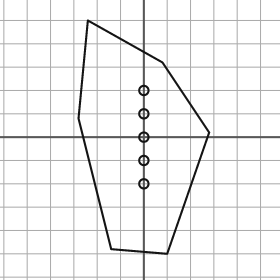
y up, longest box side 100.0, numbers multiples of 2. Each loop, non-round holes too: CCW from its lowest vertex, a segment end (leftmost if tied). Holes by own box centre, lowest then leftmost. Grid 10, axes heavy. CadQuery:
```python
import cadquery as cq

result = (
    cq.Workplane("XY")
    .moveTo(10.0, -50.0)
    .lineTo(28.0, 2.0)
    .lineTo(8.0, 32.0)
    .lineTo(-24.0, 50.0)
    .lineTo(-28.0, 8.0)
    .lineTo(-14.0, -48.0)
    .close()
    .moveTo(0.0, -20.0)
    .circle(2.0)
    .moveTo(0.0, -10.0)
    .circle(2.0)
    .moveTo(0.0, 0.0)
    .circle(2.0)
    .moveTo(0.0, 10.0)
    .circle(2.0)
    .moveTo(0.0, 20.0)
    .circle(2.0)
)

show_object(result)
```